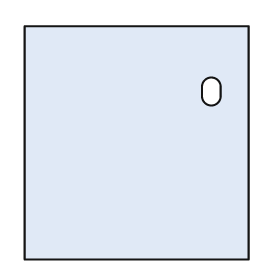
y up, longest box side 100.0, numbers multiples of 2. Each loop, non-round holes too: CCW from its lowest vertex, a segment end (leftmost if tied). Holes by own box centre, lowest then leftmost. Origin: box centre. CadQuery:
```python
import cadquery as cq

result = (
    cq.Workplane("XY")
    .moveTo(-48.0, -50.0)
    .lineTo(48.0, -50.0)
    .lineTo(48.0, 50.0)
    .lineTo(-48.0, 50.0)
    .close()
    .moveTo(28.0, 20.0)
    .threePointArc((32.0, 16.0), (36.0, 20.0))
    .lineTo(36.0, 24.0)
    .threePointArc((32.0, 28.0), (28.0, 24.0))
    .close()
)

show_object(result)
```